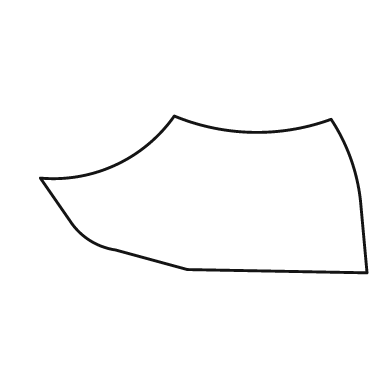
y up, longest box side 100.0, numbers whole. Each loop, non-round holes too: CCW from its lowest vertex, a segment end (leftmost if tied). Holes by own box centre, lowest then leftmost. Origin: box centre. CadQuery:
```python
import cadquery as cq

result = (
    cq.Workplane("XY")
    .moveTo(50.0, -24.0)
    .lineTo(48.0, -2.0)
    .threePointArc((45.0, 11.0), (39.0, 23.0))
    .threePointArc((15.0, 19.0), (-9.0, 24.0))
    .threePointArc((-27.0, 9.0), (-50.0, 5.0))
    .lineTo(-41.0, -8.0)
    .threePointArc((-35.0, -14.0), (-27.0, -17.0))
    .lineTo(-5.0, -23.0)
    .close()
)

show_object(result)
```